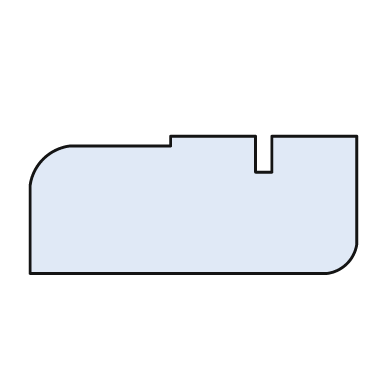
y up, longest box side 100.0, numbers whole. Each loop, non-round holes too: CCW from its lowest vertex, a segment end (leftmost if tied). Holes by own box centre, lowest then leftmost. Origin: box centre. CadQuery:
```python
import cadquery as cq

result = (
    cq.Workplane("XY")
    .moveTo(-50.0, -21.0)
    .lineTo(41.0, -21.0)
    .threePointArc((47.0, -18.0), (50.0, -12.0))
    .lineTo(50.0, 21.0)
    .lineTo(24.0, 21.0)
    .lineTo(24.0, 10.0)
    .lineTo(19.0, 10.0)
    .lineTo(19.0, 21.0)
    .lineTo(-7.0, 21.0)
    .lineTo(-7.0, 18.0)
    .lineTo(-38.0, 18.0)
    .threePointArc((-46.0, 14.0), (-50.0, 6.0))
    .close()
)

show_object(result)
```